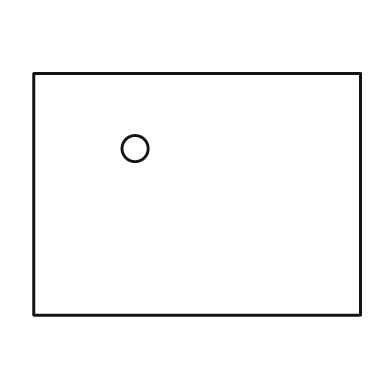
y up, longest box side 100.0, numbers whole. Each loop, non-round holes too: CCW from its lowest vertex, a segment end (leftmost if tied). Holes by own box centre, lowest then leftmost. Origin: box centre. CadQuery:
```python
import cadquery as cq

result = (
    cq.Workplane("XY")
    .moveTo(-50.0, -37.0)
    .lineTo(50.0, -37.0)
    .lineTo(50.0, 37.0)
    .lineTo(-50.0, 37.0)
    .close()
    .moveTo(-19.0, 14.0)
    .circle(4.0)
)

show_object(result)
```